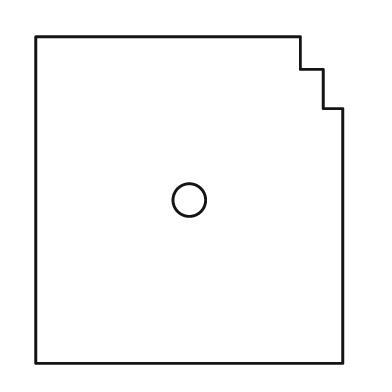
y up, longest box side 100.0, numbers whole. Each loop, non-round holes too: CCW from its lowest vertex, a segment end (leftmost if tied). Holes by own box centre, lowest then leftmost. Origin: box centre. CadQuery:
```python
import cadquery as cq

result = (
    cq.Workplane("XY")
    .moveTo(-47.0, -50.0)
    .lineTo(47.0, -50.0)
    .lineTo(47.0, 28.0)
    .lineTo(41.0, 28.0)
    .lineTo(41.0, 40.0)
    .lineTo(34.0, 40.0)
    .lineTo(34.0, 50.0)
    .lineTo(-47.0, 50.0)
    .close()
    .moveTo(0.0, 0.0)
    .circle(5.0)
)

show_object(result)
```